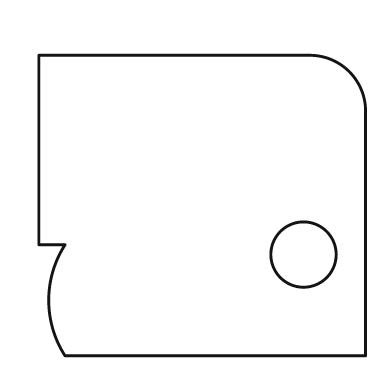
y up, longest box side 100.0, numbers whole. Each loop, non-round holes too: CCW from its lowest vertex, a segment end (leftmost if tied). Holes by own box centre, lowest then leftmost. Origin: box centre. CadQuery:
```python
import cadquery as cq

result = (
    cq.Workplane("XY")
    .moveTo(-42.0, -46.0)
    .lineTo(50.0, -46.0)
    .lineTo(50.0, 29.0)
    .threePointArc((45.0, 41.0), (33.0, 46.0))
    .lineTo(-50.0, 46.0)
    .lineTo(-50.0, -12.0)
    .lineTo(-42.0, -12.0)
    .threePointArc((-47.0, -29.0), (-42.0, -46.0))
    .close()
    .moveTo(31.0, -15.0)
    .circle(10.0)
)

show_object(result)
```